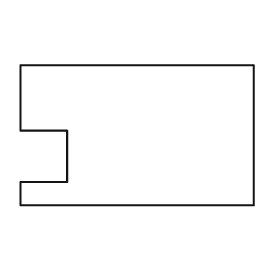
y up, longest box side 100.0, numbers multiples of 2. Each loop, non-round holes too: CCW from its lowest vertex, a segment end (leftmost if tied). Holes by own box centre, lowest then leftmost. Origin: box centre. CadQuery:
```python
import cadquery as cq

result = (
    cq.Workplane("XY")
    .moveTo(-50.0, -30.0)
    .lineTo(50.0, -30.0)
    .lineTo(50.0, 30.0)
    .lineTo(-50.0, 30.0)
    .lineTo(-50.0, 2.0)
    .lineTo(-30.0, 2.0)
    .lineTo(-30.0, -20.0)
    .lineTo(-50.0, -20.0)
    .close()
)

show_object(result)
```